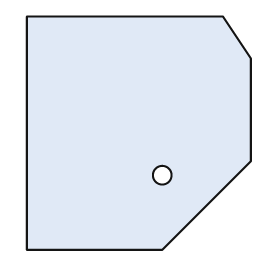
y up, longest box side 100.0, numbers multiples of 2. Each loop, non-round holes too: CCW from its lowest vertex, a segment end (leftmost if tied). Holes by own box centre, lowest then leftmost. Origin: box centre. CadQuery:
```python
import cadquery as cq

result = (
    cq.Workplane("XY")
    .moveTo(-48.0, -50.0)
    .lineTo(10.0, -50.0)
    .lineTo(48.0, -12.0)
    .lineTo(48.0, 32.0)
    .lineTo(36.0, 50.0)
    .lineTo(-48.0, 50.0)
    .close()
    .moveTo(10.0, -18.0)
    .circle(4.0)
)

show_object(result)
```